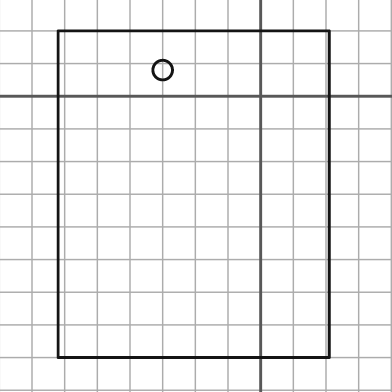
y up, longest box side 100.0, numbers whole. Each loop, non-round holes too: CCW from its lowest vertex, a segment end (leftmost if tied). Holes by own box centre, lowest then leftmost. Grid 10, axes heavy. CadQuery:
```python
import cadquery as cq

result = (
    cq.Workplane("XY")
    .moveTo(-62.0, -80.0)
    .lineTo(21.0, -80.0)
    .lineTo(21.0, 20.0)
    .lineTo(-62.0, 20.0)
    .close()
    .moveTo(-30.0, 8.0)
    .circle(3.0)
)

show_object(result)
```